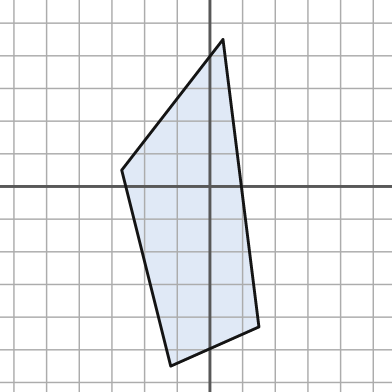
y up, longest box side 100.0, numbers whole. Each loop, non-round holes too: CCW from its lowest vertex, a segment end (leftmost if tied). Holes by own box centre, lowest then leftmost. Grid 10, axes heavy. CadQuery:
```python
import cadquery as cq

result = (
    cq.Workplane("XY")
    .moveTo(-12.0, -55.0)
    .lineTo(15.0, -43.0)
    .lineTo(4.0, 45.0)
    .lineTo(-27.0, 5.0)
    .close()
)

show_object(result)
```